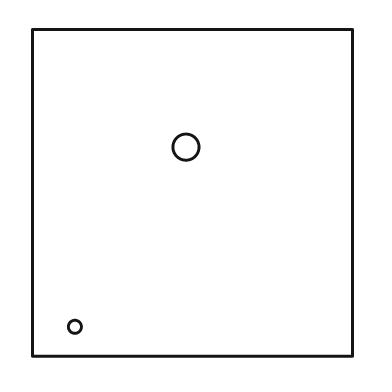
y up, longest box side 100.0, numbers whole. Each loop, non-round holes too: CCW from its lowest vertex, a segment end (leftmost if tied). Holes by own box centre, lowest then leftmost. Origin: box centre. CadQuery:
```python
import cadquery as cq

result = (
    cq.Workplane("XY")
    .moveTo(-49.0, -50.0)
    .lineTo(49.0, -50.0)
    .lineTo(49.0, 50.0)
    .lineTo(-49.0, 50.0)
    .close()
    .moveTo(-36.0, -41.0)
    .circle(2.0)
    .moveTo(-2.0, 14.0)
    .circle(4.0)
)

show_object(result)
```